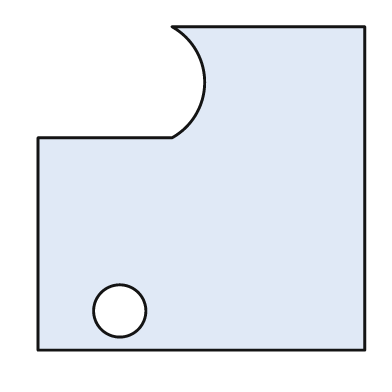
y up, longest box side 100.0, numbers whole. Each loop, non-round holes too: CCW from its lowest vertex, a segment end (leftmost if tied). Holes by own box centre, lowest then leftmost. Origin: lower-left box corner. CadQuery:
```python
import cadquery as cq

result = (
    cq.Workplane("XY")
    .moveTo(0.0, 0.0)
    .lineTo(100.0, 0.0)
    .lineTo(100.0, 99.0)
    .lineTo(41.0, 99.0)
    .threePointArc((51.0, 82.0), (41.0, 65.0))
    .lineTo(0.0, 65.0)
    .close()
    .moveTo(25.0, 12.0)
    .circle(8.0)
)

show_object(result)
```